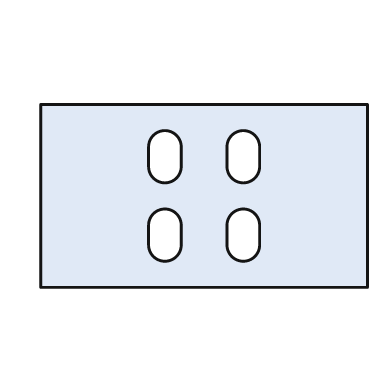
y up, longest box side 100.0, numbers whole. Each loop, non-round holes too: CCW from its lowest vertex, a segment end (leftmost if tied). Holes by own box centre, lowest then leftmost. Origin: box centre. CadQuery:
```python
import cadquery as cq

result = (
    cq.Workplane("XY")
    .moveTo(-50.0, -28.0)
    .lineTo(50.0, -28.0)
    .lineTo(50.0, 28.0)
    .lineTo(-50.0, 28.0)
    .close()
    .moveTo(-17.0, -15.0)
    .threePointArc((-12.0, -20.0), (-7.0, -15.0))
    .lineTo(-7.0, -9.0)
    .threePointArc((-12.0, -4.0), (-17.0, -9.0))
    .close()
    .moveTo(7.0, -15.0)
    .threePointArc((12.0, -20.0), (17.0, -15.0))
    .lineTo(17.0, -9.0)
    .threePointArc((12.0, -4.0), (7.0, -9.0))
    .close()
    .moveTo(-17.0, 9.0)
    .threePointArc((-12.0, 4.0), (-7.0, 9.0))
    .lineTo(-7.0, 15.0)
    .threePointArc((-12.0, 20.0), (-17.0, 15.0))
    .close()
    .moveTo(7.0, 9.0)
    .threePointArc((12.0, 4.0), (17.0, 9.0))
    .lineTo(17.0, 15.0)
    .threePointArc((12.0, 20.0), (7.0, 15.0))
    .close()
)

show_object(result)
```